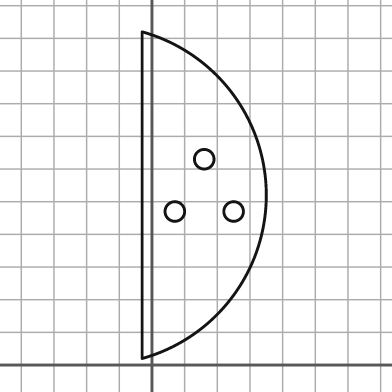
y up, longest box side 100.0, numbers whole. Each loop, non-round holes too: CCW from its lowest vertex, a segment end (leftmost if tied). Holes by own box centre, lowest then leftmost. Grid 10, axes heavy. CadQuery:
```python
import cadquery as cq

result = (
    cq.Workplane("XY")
    .moveTo(-3.0, 2.0)
    .threePointArc((35.0, 52.0), (-3.0, 102.0))
    .close()
    .moveTo(7.0, 47.0)
    .circle(3.0)
    .moveTo(25.0, 47.0)
    .circle(3.0)
    .moveTo(16.0, 63.0)
    .circle(3.0)
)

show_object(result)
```